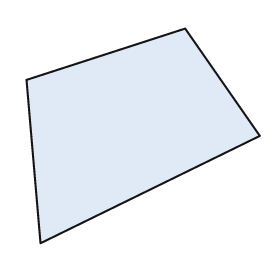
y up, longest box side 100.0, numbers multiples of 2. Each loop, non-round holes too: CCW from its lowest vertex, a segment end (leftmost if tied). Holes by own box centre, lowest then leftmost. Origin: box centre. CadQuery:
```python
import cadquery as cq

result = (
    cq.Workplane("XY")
    .moveTo(-44.0, -46.0)
    .lineTo(50.0, 0.0)
    .lineTo(18.0, 46.0)
    .lineTo(-50.0, 24.0)
    .close()
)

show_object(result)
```